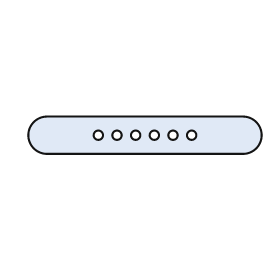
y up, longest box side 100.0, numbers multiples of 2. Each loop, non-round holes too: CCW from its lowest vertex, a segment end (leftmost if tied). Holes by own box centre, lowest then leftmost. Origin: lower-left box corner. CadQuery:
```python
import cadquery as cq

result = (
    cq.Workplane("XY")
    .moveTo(8.0, 0.0)
    .lineTo(92.0, 0.0)
    .threePointArc((100.0, 8.0), (92.0, 16.0))
    .lineTo(8.0, 16.0)
    .threePointArc((0.0, 8.0), (8.0, 0.0))
    .close()
    .moveTo(30.0, 8.0)
    .circle(2.0)
    .moveTo(38.0, 8.0)
    .circle(2.0)
    .moveTo(46.0, 8.0)
    .circle(2.0)
    .moveTo(54.0, 8.0)
    .circle(2.0)
    .moveTo(62.0, 8.0)
    .circle(2.0)
    .moveTo(70.0, 8.0)
    .circle(2.0)
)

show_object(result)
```